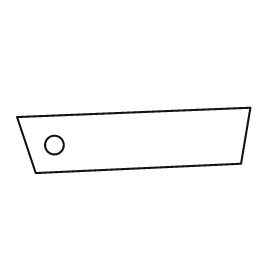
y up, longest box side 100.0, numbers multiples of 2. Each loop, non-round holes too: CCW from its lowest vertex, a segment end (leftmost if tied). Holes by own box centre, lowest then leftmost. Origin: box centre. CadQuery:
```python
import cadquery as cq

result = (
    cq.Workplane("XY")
    .moveTo(-42.0, -14.0)
    .lineTo(46.0, -10.0)
    .lineTo(50.0, 14.0)
    .lineTo(-50.0, 10.0)
    .close()
    .moveTo(-34.0, -2.0)
    .circle(4.0)
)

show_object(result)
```